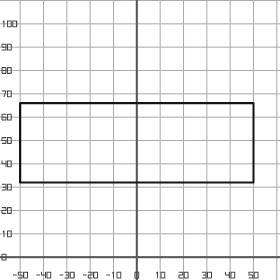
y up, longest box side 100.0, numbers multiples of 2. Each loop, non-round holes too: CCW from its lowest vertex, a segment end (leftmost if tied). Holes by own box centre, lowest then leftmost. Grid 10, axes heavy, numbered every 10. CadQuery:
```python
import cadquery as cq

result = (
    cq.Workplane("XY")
    .moveTo(-50.0, 32.0)
    .lineTo(50.0, 32.0)
    .lineTo(50.0, 66.0)
    .lineTo(-50.0, 66.0)
    .close()
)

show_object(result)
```